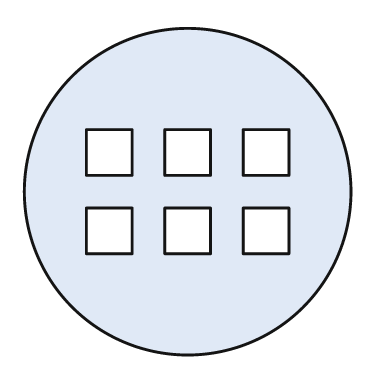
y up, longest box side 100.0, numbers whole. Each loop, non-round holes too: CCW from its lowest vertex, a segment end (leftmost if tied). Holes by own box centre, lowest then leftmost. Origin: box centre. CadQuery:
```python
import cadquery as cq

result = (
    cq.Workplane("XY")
    .moveTo(0.0, 0.0)
    .circle(50.0)
    .moveTo(-31.0, -19.0)
    .lineTo(-17.0, -19.0)
    .lineTo(-17.0, -5.0)
    .lineTo(-31.0, -5.0)
    .close()
    .moveTo(-7.0, -19.0)
    .lineTo(7.0, -19.0)
    .lineTo(7.0, -5.0)
    .lineTo(-7.0, -5.0)
    .close()
    .moveTo(17.0, -19.0)
    .lineTo(31.0, -19.0)
    .lineTo(31.0, -5.0)
    .lineTo(17.0, -5.0)
    .close()
    .moveTo(-31.0, 5.0)
    .lineTo(-17.0, 5.0)
    .lineTo(-17.0, 19.0)
    .lineTo(-31.0, 19.0)
    .close()
    .moveTo(-7.0, 5.0)
    .lineTo(7.0, 5.0)
    .lineTo(7.0, 19.0)
    .lineTo(-7.0, 19.0)
    .close()
    .moveTo(17.0, 5.0)
    .lineTo(31.0, 5.0)
    .lineTo(31.0, 19.0)
    .lineTo(17.0, 19.0)
    .close()
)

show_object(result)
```